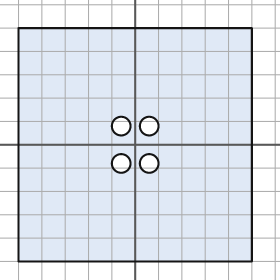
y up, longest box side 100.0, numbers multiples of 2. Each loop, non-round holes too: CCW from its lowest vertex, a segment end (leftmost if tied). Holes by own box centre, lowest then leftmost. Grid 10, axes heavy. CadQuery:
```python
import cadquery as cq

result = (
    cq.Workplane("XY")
    .moveTo(-50.0, -50.0)
    .lineTo(50.0, -50.0)
    .lineTo(50.0, 50.0)
    .lineTo(-50.0, 50.0)
    .close()
    .moveTo(-6.0, -8.0)
    .circle(4.0)
    .moveTo(6.0, -8.0)
    .circle(4.0)
    .moveTo(-6.0, 8.0)
    .circle(4.0)
    .moveTo(6.0, 8.0)
    .circle(4.0)
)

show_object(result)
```